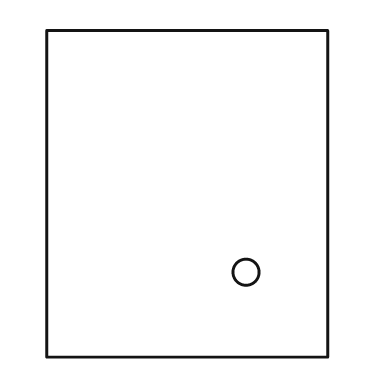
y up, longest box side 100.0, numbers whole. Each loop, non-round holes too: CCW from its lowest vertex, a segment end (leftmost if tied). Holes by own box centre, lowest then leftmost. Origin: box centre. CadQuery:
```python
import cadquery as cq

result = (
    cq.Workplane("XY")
    .moveTo(-43.0, -50.0)
    .lineTo(43.0, -50.0)
    .lineTo(43.0, 50.0)
    .lineTo(-43.0, 50.0)
    .close()
    .moveTo(18.0, -24.0)
    .circle(4.0)
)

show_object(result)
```